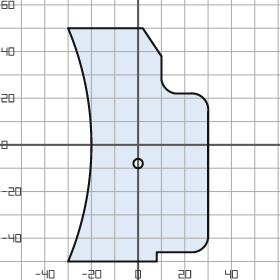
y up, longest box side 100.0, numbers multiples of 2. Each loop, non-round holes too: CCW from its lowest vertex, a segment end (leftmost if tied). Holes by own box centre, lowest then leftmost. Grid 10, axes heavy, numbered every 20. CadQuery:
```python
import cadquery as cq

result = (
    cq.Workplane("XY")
    .moveTo(-30.0, -50.0)
    .lineTo(8.0, -50.0)
    .lineTo(8.0, -46.0)
    .lineTo(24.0, -46.0)
    .threePointArc((28.0, -44.0), (30.0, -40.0))
    .lineTo(30.0, 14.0)
    .threePointArc((28.0, 20.0), (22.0, 22.0))
    .lineTo(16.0, 22.0)
    .threePointArc((12.0, 24.0), (10.0, 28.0))
    .lineTo(10.0, 38.0)
    .lineTo(2.0, 50.0)
    .lineTo(-30.0, 50.0)
    .threePointArc((-20.0, 0.0), (-30.0, -50.0))
    .close()
    .moveTo(0.0, -8.0)
    .circle(2.0)
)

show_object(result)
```